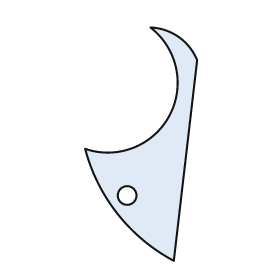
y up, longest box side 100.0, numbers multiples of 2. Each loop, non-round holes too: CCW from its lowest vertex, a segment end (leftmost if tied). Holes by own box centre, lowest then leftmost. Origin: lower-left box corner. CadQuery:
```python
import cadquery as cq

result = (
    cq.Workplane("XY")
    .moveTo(38.0, 0.0)
    .lineTo(48.0, 86.0)
    .threePointArc((40.0, 96.0), (28.0, 100.0))
    .threePointArc((36.0, 62.0), (0.0, 48.0))
    .threePointArc((14.0, 20.0), (38.0, 0.0))
    .close()
    .moveTo(18.0, 28.0)
    .circle(4.0)
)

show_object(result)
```